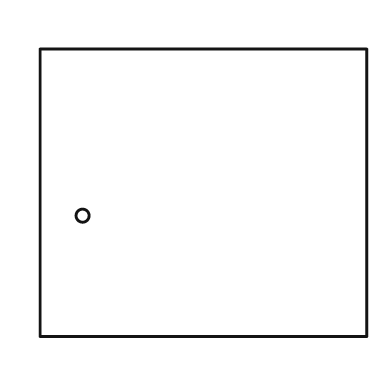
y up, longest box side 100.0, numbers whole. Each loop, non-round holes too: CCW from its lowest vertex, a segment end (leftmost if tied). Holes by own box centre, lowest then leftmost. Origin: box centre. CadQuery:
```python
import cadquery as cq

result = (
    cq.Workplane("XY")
    .moveTo(-50.0, -44.0)
    .lineTo(50.0, -44.0)
    .lineTo(50.0, 44.0)
    .lineTo(-50.0, 44.0)
    .close()
    .moveTo(-37.0, -7.0)
    .circle(2.0)
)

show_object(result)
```